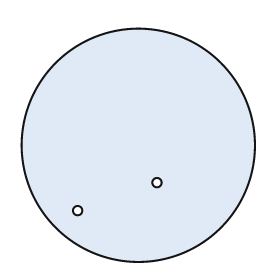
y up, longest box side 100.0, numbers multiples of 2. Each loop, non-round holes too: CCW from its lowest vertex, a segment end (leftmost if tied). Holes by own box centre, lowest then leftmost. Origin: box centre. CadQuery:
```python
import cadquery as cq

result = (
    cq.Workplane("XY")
    .moveTo(0.0, 0.0)
    .circle(50.0)
    .moveTo(-26.0, -28.0)
    .circle(2.0)
    .moveTo(8.0, -16.0)
    .circle(2.0)
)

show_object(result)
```